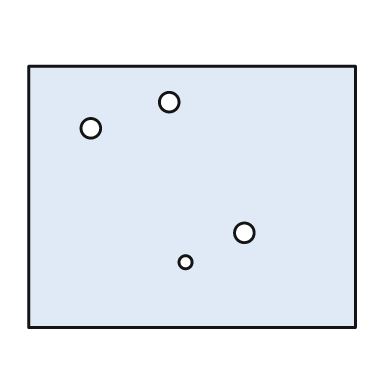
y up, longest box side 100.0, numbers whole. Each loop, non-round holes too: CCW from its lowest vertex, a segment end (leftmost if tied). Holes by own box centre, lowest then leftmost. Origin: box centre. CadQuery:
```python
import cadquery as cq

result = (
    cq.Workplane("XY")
    .moveTo(-50.0, -40.0)
    .lineTo(50.0, -40.0)
    .lineTo(50.0, 40.0)
    .lineTo(-50.0, 40.0)
    .close()
    .moveTo(-2.0, -20.0)
    .circle(2.0)
    .moveTo(16.0, -11.0)
    .circle(3.0)
    .moveTo(-31.0, 21.0)
    .circle(3.0)
    .moveTo(-7.0, 29.0)
    .circle(3.0)
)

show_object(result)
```